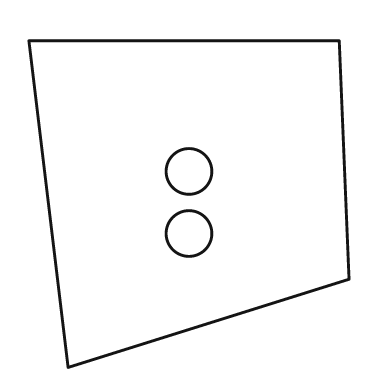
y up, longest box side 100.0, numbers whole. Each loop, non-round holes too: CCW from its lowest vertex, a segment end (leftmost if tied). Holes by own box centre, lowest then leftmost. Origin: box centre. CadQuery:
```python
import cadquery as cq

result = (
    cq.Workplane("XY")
    .moveTo(-37.0, -50.0)
    .lineTo(49.0, -23.0)
    .lineTo(46.0, 50.0)
    .lineTo(-49.0, 50.0)
    .close()
    .moveTo(0.0, -9.0)
    .circle(7.0)
    .moveTo(0.0, 10.0)
    .circle(7.0)
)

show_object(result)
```